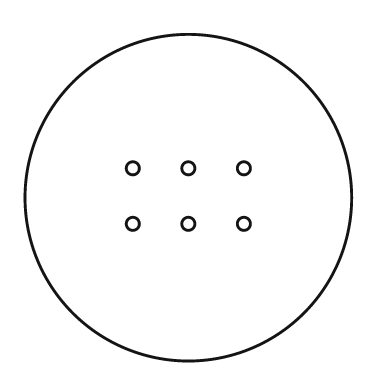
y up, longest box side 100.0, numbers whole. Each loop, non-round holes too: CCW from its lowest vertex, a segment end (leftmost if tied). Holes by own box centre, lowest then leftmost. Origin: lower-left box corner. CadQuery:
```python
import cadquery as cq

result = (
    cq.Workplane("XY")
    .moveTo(50.0, 50.0)
    .circle(50.0)
    .moveTo(33.0, 42.0)
    .circle(2.0)
    .moveTo(50.0, 42.0)
    .circle(2.0)
    .moveTo(67.0, 42.0)
    .circle(2.0)
    .moveTo(33.0, 59.0)
    .circle(2.0)
    .moveTo(50.0, 59.0)
    .circle(2.0)
    .moveTo(67.0, 59.0)
    .circle(2.0)
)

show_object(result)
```